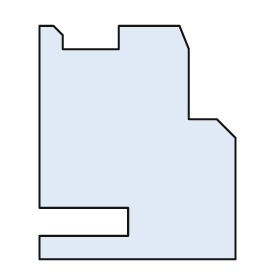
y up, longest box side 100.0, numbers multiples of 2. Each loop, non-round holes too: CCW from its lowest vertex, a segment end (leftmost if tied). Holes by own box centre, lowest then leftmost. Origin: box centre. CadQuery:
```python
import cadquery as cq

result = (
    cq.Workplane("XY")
    .moveTo(-42.0, -50.0)
    .lineTo(42.0, -50.0)
    .lineTo(42.0, 2.0)
    .lineTo(34.0, 10.0)
    .lineTo(22.0, 10.0)
    .lineTo(22.0, 40.0)
    .lineTo(18.0, 50.0)
    .lineTo(-8.0, 50.0)
    .lineTo(-8.0, 40.0)
    .lineTo(-32.0, 40.0)
    .lineTo(-32.0, 46.0)
    .lineTo(-36.0, 50.0)
    .lineTo(-42.0, 50.0)
    .lineTo(-42.0, -28.0)
    .lineTo(-4.0, -28.0)
    .lineTo(-4.0, -40.0)
    .lineTo(-42.0, -40.0)
    .close()
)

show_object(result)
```